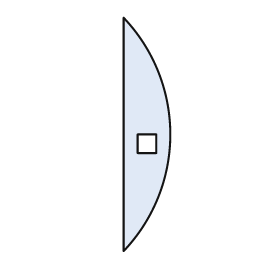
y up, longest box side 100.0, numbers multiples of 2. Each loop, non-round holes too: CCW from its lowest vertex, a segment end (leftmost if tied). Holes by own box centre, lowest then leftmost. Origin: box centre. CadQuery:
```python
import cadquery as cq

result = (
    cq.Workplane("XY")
    .moveTo(-10.0, -50.0)
    .threePointArc((10.0, 0.0), (-10.0, 50.0))
    .close()
    .moveTo(-4.0, -8.0)
    .lineTo(4.0, -8.0)
    .lineTo(4.0, 0.0)
    .lineTo(-4.0, 0.0)
    .close()
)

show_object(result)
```